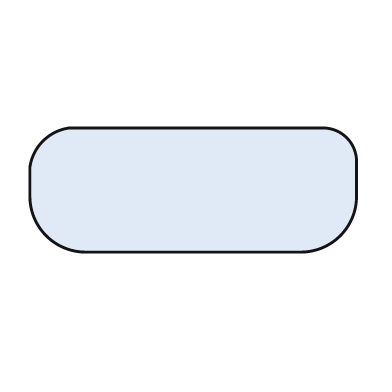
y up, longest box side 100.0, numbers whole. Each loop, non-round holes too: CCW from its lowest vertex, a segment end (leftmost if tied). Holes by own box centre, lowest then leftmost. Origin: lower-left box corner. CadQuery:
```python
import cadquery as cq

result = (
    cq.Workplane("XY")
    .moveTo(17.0, 0.0)
    .lineTo(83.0, 0.0)
    .threePointArc((95.0, 5.0), (100.0, 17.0))
    .lineTo(100.0, 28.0)
    .threePointArc((97.0, 35.0), (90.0, 38.0))
    .lineTo(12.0, 38.0)
    .threePointArc((4.0, 34.0), (0.0, 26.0))
    .lineTo(0.0, 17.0)
    .threePointArc((5.0, 5.0), (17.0, 0.0))
    .close()
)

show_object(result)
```